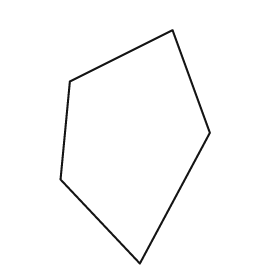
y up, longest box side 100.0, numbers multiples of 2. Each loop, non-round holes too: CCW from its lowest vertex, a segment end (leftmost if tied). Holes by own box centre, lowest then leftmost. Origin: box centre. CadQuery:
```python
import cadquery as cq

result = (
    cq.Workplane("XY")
    .moveTo(2.0, -50.0)
    .lineTo(32.0, 6.0)
    .lineTo(16.0, 50.0)
    .lineTo(-28.0, 28.0)
    .lineTo(-32.0, -14.0)
    .close()
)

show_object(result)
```